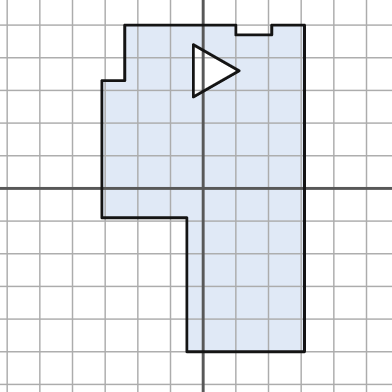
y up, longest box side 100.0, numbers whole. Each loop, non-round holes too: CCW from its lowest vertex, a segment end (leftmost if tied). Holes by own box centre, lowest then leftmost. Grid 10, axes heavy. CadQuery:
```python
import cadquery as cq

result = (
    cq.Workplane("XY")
    .moveTo(-5.0, -50.0)
    .lineTo(31.0, -50.0)
    .lineTo(31.0, 50.0)
    .lineTo(21.0, 50.0)
    .lineTo(21.0, 47.0)
    .lineTo(10.0, 47.0)
    .lineTo(10.0, 50.0)
    .lineTo(-24.0, 50.0)
    .lineTo(-24.0, 33.0)
    .lineTo(-31.0, 33.0)
    .lineTo(-31.0, -9.0)
    .lineTo(-5.0, -9.0)
    .close()
    .moveTo(-3.0, 28.0)
    .lineTo(11.0, 36.0)
    .lineTo(-3.0, 44.0)
    .close()
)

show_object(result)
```